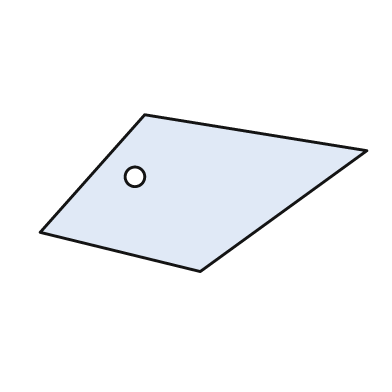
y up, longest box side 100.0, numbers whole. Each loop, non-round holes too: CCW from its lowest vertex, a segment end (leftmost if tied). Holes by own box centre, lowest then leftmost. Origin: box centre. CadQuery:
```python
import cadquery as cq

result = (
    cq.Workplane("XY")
    .moveTo(-1.0, -24.0)
    .lineTo(50.0, 13.0)
    .lineTo(-18.0, 24.0)
    .lineTo(-50.0, -12.0)
    .close()
    .moveTo(-21.0, 5.0)
    .circle(3.0)
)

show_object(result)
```